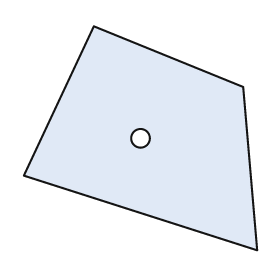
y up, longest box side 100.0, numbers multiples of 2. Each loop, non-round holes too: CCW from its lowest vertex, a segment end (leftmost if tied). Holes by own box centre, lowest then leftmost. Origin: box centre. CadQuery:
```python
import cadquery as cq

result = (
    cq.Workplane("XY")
    .moveTo(50.0, -48.0)
    .lineTo(44.0, 22.0)
    .lineTo(-20.0, 48.0)
    .lineTo(-50.0, -16.0)
    .close()
    .moveTo(0.0, 0.0)
    .circle(4.0)
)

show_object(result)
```